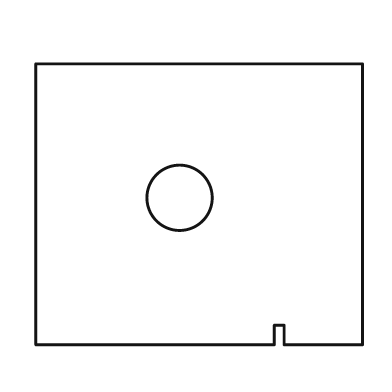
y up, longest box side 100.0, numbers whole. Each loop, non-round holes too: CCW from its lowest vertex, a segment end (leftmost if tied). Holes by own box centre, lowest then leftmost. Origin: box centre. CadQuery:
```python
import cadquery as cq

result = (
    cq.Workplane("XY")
    .moveTo(-50.0, -43.0)
    .lineTo(23.0, -43.0)
    .lineTo(23.0, -37.0)
    .lineTo(26.0, -37.0)
    .lineTo(26.0, -43.0)
    .lineTo(50.0, -43.0)
    .lineTo(50.0, 43.0)
    .lineTo(-50.0, 43.0)
    .close()
    .moveTo(-6.0, 2.0)
    .circle(10.0)
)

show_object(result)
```